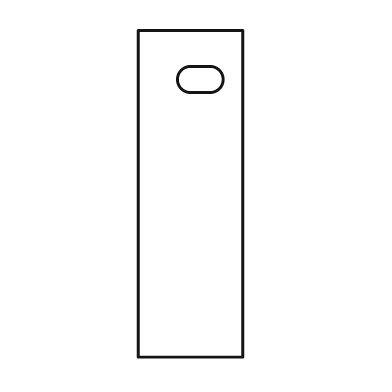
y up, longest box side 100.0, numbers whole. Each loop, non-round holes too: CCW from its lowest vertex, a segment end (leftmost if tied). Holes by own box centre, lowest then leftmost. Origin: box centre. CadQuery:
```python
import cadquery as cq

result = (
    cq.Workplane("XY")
    .moveTo(-16.0, -50.0)
    .lineTo(16.0, -50.0)
    .lineTo(16.0, 50.0)
    .lineTo(-16.0, 50.0)
    .close()
    .moveTo(0.0, 31.0)
    .lineTo(6.0, 31.0)
    .threePointArc((10.0, 35.0), (6.0, 39.0))
    .lineTo(0.0, 39.0)
    .threePointArc((-4.0, 35.0), (0.0, 31.0))
    .close()
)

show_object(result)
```